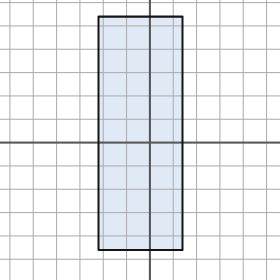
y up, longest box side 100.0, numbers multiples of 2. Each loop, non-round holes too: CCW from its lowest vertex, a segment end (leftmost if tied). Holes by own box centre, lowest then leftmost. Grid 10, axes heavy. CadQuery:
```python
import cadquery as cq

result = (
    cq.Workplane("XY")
    .moveTo(-22.0, -46.0)
    .lineTo(14.0, -46.0)
    .lineTo(14.0, 54.0)
    .lineTo(-22.0, 54.0)
    .close()
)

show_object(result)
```